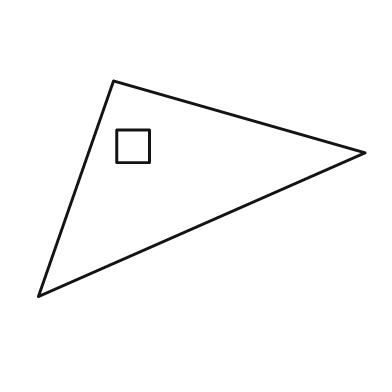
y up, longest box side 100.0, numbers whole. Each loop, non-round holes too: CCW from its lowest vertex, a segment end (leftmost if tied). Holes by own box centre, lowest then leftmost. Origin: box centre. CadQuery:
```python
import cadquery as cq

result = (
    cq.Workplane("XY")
    .moveTo(-50.0, -33.0)
    .lineTo(50.0, 11.0)
    .lineTo(-27.0, 33.0)
    .close()
    .moveTo(-26.0, 8.0)
    .lineTo(-16.0, 8.0)
    .lineTo(-16.0, 18.0)
    .lineTo(-26.0, 18.0)
    .close()
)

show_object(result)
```